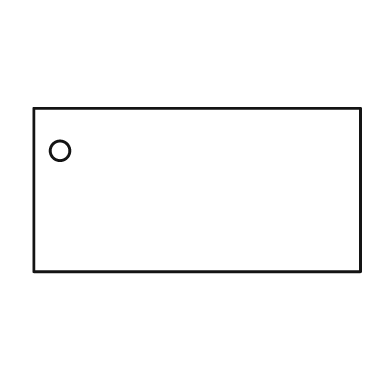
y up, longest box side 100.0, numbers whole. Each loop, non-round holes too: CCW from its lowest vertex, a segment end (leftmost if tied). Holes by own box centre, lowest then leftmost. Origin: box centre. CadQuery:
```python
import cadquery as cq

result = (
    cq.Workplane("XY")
    .moveTo(-50.0, -25.0)
    .lineTo(50.0, -25.0)
    .lineTo(50.0, 25.0)
    .lineTo(-50.0, 25.0)
    .close()
    .moveTo(-42.0, 12.0)
    .circle(3.0)
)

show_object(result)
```